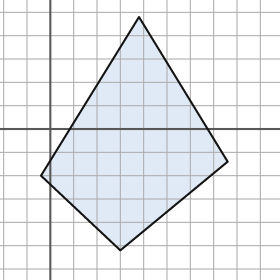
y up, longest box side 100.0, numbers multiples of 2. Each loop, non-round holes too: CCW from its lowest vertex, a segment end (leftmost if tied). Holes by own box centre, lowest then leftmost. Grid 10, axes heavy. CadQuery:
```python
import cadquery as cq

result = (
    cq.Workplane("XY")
    .moveTo(30.0, -52.0)
    .lineTo(76.0, -14.0)
    .lineTo(38.0, 48.0)
    .lineTo(-4.0, -20.0)
    .close()
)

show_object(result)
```